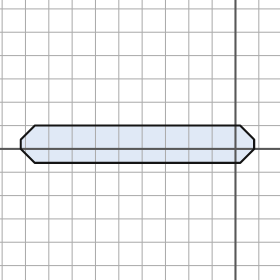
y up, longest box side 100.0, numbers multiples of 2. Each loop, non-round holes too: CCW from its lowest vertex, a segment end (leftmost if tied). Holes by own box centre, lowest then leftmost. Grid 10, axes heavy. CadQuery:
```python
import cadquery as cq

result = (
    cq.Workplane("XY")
    .moveTo(-86.0, -6.0)
    .lineTo(2.0, -6.0)
    .lineTo(8.0, 0.0)
    .lineTo(8.0, 4.0)
    .lineTo(2.0, 10.0)
    .lineTo(-86.0, 10.0)
    .lineTo(-92.0, 4.0)
    .lineTo(-92.0, 0.0)
    .close()
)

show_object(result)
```